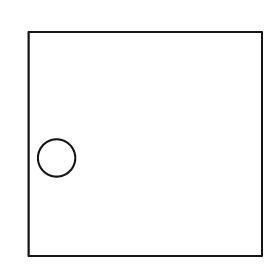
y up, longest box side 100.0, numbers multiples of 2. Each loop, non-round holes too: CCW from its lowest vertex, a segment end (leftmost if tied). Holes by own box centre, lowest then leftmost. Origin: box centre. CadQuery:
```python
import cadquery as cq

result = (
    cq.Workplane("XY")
    .moveTo(-50.0, -48.0)
    .lineTo(50.0, -48.0)
    .lineTo(50.0, 48.0)
    .lineTo(-50.0, 48.0)
    .close()
    .moveTo(-38.0, -6.0)
    .circle(8.0)
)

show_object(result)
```